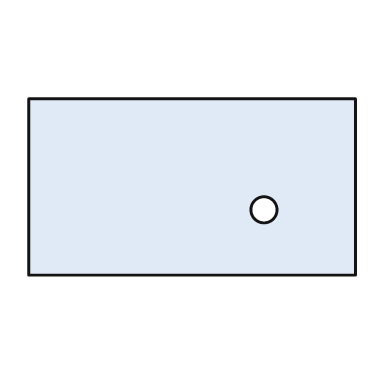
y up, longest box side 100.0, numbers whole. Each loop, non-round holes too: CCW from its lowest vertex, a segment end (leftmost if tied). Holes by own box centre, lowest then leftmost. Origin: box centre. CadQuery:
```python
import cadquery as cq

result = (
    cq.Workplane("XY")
    .moveTo(-50.0, -27.0)
    .lineTo(50.0, -27.0)
    .lineTo(50.0, 27.0)
    .lineTo(-50.0, 27.0)
    .close()
    .moveTo(22.0, -7.0)
    .circle(4.0)
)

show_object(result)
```